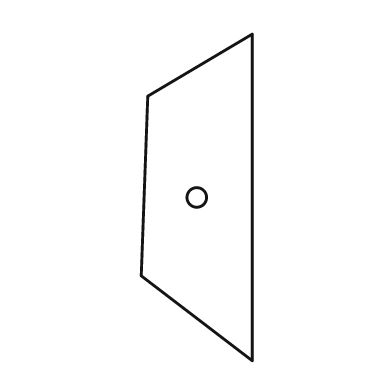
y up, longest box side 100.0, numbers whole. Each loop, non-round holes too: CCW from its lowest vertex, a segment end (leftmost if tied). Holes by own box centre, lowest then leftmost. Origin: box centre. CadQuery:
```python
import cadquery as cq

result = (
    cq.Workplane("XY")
    .moveTo(17.0, -50.0)
    .lineTo(17.0, 50.0)
    .lineTo(-15.0, 31.0)
    .lineTo(-17.0, -24.0)
    .close()
    .moveTo(0.0, 0.0)
    .circle(3.0)
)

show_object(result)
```